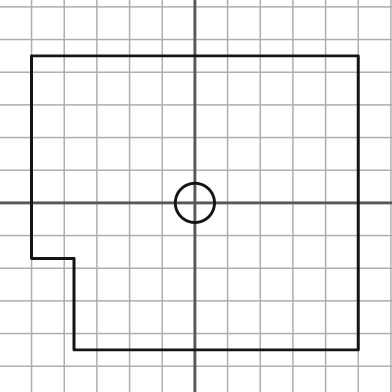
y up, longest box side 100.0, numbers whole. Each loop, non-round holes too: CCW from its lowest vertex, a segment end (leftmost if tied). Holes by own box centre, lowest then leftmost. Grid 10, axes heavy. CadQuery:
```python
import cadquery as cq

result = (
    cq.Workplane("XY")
    .moveTo(-37.0, -45.0)
    .lineTo(50.0, -45.0)
    .lineTo(50.0, 45.0)
    .lineTo(-50.0, 45.0)
    .lineTo(-50.0, -17.0)
    .lineTo(-37.0, -17.0)
    .close()
    .moveTo(0.0, 0.0)
    .circle(6.0)
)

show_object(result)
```